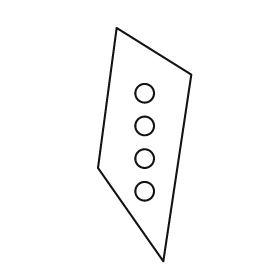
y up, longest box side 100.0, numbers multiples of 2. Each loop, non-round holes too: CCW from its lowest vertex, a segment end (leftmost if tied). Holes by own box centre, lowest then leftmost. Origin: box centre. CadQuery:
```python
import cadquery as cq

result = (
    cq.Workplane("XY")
    .moveTo(8.0, -50.0)
    .lineTo(20.0, 30.0)
    .lineTo(-12.0, 50.0)
    .lineTo(-20.0, -10.0)
    .close()
    .moveTo(0.0, -20.0)
    .circle(4.0)
    .moveTo(0.0, -6.0)
    .circle(4.0)
    .moveTo(0.0, 8.0)
    .circle(4.0)
    .moveTo(0.0, 22.0)
    .circle(4.0)
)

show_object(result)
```